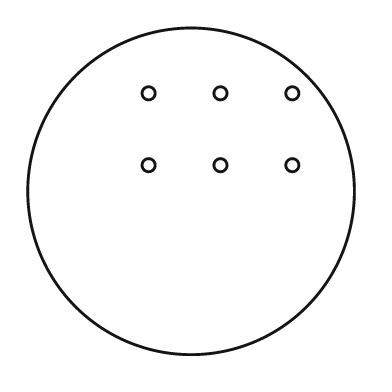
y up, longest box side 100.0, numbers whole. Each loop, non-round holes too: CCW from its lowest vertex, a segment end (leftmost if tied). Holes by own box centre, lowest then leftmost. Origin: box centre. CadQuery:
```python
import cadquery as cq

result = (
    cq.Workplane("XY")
    .moveTo(0.0, 0.0)
    .circle(50.0)
    .moveTo(-13.0, 8.0)
    .circle(2.0)
    .moveTo(9.0, 8.0)
    .circle(2.0)
    .moveTo(31.0, 8.0)
    .circle(2.0)
    .moveTo(-13.0, 30.0)
    .circle(2.0)
    .moveTo(9.0, 30.0)
    .circle(2.0)
    .moveTo(31.0, 30.0)
    .circle(2.0)
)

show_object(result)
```